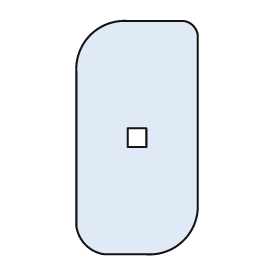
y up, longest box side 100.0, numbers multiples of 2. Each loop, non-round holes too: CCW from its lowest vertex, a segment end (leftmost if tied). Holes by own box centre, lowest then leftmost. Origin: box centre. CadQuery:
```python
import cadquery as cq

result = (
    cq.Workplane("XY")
    .moveTo(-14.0, -50.0)
    .lineTo(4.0, -50.0)
    .threePointArc((20.0, -44.0), (26.0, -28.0))
    .lineTo(26.0, 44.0)
    .threePointArc((24.0, 48.0), (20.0, 50.0))
    .lineTo(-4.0, 50.0)
    .threePointArc((-20.0, 44.0), (-26.0, 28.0))
    .lineTo(-26.0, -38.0)
    .threePointArc((-22.0, -46.0), (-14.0, -50.0))
    .close()
    .moveTo(-4.0, -4.0)
    .lineTo(4.0, -4.0)
    .lineTo(4.0, 4.0)
    .lineTo(-4.0, 4.0)
    .close()
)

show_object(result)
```